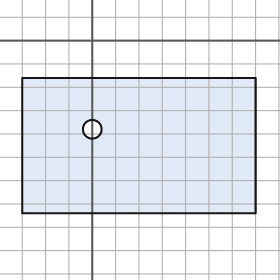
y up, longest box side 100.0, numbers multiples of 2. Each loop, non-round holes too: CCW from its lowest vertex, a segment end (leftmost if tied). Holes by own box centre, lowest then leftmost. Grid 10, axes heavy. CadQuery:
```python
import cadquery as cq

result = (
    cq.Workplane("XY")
    .moveTo(-30.0, -74.0)
    .lineTo(70.0, -74.0)
    .lineTo(70.0, -16.0)
    .lineTo(-30.0, -16.0)
    .close()
    .moveTo(0.0, -38.0)
    .circle(4.0)
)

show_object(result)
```